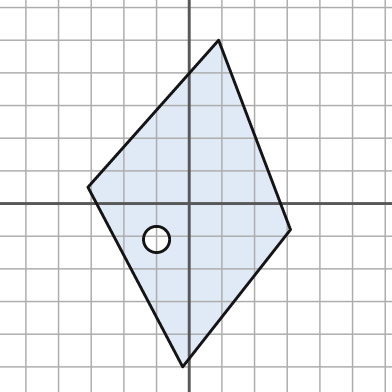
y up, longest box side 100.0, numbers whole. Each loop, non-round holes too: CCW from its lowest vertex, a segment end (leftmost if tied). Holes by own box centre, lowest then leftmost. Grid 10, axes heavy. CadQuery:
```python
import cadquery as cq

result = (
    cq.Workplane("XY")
    .moveTo(-2.0, -50.0)
    .lineTo(31.0, -8.0)
    .lineTo(9.0, 50.0)
    .lineTo(-31.0, 5.0)
    .close()
    .moveTo(-10.0, -11.0)
    .circle(4.0)
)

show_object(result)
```